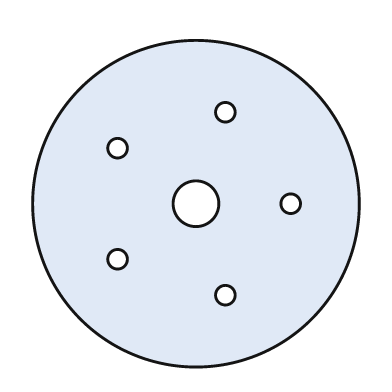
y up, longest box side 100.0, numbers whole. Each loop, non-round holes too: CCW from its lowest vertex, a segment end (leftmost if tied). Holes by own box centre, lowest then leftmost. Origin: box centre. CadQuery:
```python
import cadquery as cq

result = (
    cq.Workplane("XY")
    .moveTo(0.0, 0.0)
    .circle(50.0)
    .moveTo(9.0, -28.0)
    .circle(3.0)
    .moveTo(-24.0, -17.0)
    .circle(3.0)
    .moveTo(0.0, 0.0)
    .circle(7.0)
    .moveTo(29.0, 0.0)
    .circle(3.0)
    .moveTo(-24.0, 17.0)
    .circle(3.0)
    .moveTo(9.0, 28.0)
    .circle(3.0)
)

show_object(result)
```